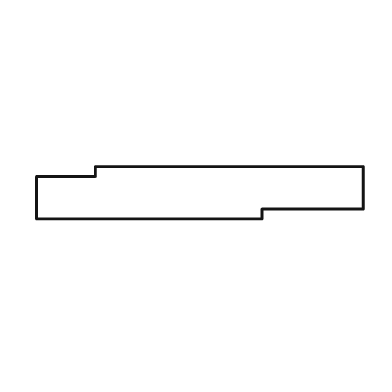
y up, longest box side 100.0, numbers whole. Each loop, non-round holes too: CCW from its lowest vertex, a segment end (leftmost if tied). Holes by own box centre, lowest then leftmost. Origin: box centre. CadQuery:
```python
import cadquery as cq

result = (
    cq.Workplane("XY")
    .moveTo(-50.0, -8.0)
    .lineTo(19.0, -8.0)
    .lineTo(19.0, -5.0)
    .lineTo(50.0, -5.0)
    .lineTo(50.0, 8.0)
    .lineTo(-32.0, 8.0)
    .lineTo(-32.0, 5.0)
    .lineTo(-50.0, 5.0)
    .close()
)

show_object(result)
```